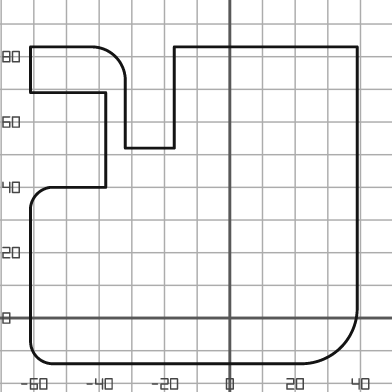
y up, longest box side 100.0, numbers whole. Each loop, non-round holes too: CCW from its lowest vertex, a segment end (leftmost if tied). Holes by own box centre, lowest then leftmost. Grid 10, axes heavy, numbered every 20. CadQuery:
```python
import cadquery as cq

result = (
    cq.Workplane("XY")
    .moveTo(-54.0, -14.0)
    .lineTo(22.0, -14.0)
    .threePointArc((34.0, -9.0), (39.0, 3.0))
    .lineTo(39.0, 83.0)
    .lineTo(-17.0, 83.0)
    .lineTo(-17.0, 52.0)
    .lineTo(-32.0, 52.0)
    .lineTo(-32.0, 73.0)
    .threePointArc((-35.0, 80.0), (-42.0, 83.0))
    .lineTo(-61.0, 83.0)
    .lineTo(-61.0, 69.0)
    .lineTo(-38.0, 69.0)
    .lineTo(-38.0, 40.0)
    .lineTo(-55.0, 40.0)
    .threePointArc((-59.0, 38.0), (-61.0, 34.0))
    .lineTo(-61.0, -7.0)
    .threePointArc((-59.0, -12.0), (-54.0, -14.0))
    .close()
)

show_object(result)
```